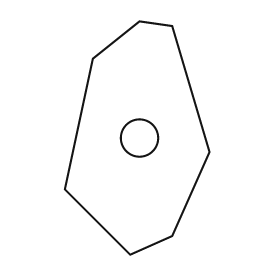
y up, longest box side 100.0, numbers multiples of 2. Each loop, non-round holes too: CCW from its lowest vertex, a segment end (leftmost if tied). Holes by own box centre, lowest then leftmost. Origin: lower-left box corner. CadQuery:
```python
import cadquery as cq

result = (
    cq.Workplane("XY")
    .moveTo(28.0, 0.0)
    .lineTo(46.0, 8.0)
    .lineTo(62.0, 44.0)
    .lineTo(46.0, 98.0)
    .lineTo(32.0, 100.0)
    .lineTo(12.0, 84.0)
    .lineTo(0.0, 28.0)
    .close()
    .moveTo(32.0, 50.0)
    .circle(8.0)
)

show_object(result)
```